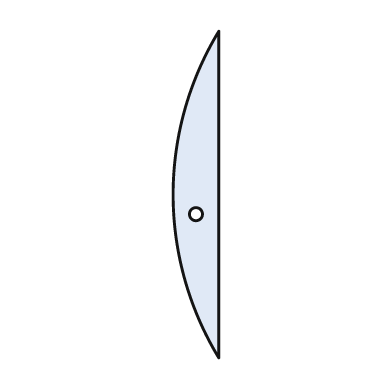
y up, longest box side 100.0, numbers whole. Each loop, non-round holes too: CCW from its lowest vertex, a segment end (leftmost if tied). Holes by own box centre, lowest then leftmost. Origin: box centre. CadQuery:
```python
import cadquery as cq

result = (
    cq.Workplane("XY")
    .moveTo(7.0, -50.0)
    .lineTo(7.0, 50.0)
    .threePointArc((-7.0, 0.0), (7.0, -50.0))
    .close()
    .moveTo(0.0, -6.0)
    .circle(2.0)
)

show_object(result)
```